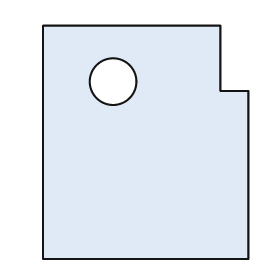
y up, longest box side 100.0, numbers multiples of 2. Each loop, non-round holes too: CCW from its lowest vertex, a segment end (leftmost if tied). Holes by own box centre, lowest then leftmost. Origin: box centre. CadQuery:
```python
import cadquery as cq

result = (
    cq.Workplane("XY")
    .moveTo(-44.0, -50.0)
    .lineTo(44.0, -50.0)
    .lineTo(44.0, 22.0)
    .lineTo(32.0, 22.0)
    .lineTo(32.0, 50.0)
    .lineTo(-44.0, 50.0)
    .close()
    .moveTo(-14.0, 26.0)
    .circle(10.0)
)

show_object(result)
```